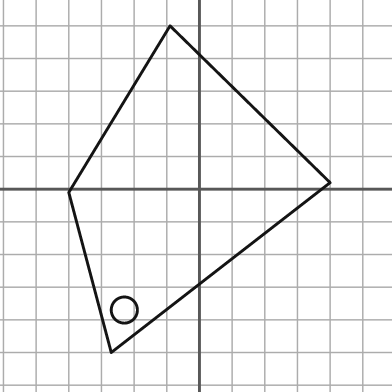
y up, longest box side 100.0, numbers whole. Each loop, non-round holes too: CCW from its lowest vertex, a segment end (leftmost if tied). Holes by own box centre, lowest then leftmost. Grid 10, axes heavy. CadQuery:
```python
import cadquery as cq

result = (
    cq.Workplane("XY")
    .moveTo(-27.0, -50.0)
    .lineTo(40.0, 2.0)
    .lineTo(-9.0, 50.0)
    .lineTo(-40.0, -1.0)
    .close()
    .moveTo(-23.0, -37.0)
    .circle(4.0)
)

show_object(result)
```